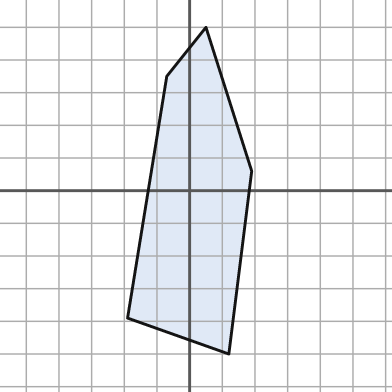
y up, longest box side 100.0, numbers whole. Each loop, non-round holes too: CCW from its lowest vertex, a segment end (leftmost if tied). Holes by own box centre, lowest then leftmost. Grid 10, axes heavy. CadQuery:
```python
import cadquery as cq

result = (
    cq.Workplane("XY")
    .moveTo(12.0, -50.0)
    .lineTo(19.0, 6.0)
    .lineTo(5.0, 50.0)
    .lineTo(-7.0, 35.0)
    .lineTo(-19.0, -39.0)
    .close()
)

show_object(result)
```